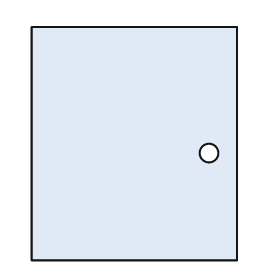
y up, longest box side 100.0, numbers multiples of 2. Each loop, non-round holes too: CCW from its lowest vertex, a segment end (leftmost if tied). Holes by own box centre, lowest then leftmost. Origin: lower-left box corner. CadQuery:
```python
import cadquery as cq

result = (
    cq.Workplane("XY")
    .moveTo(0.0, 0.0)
    .lineTo(88.0, 0.0)
    .lineTo(88.0, 100.0)
    .lineTo(0.0, 100.0)
    .close()
    .moveTo(76.0, 46.0)
    .circle(4.0)
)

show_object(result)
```